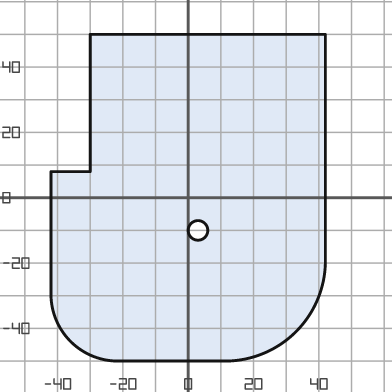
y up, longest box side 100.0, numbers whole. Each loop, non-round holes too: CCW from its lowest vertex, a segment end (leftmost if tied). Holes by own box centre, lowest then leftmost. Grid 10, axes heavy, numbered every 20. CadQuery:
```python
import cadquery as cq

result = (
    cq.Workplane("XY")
    .moveTo(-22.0, -50.0)
    .lineTo(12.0, -50.0)
    .threePointArc((33.0, -41.0), (42.0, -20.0))
    .lineTo(42.0, 50.0)
    .lineTo(-30.0, 50.0)
    .lineTo(-30.0, 8.0)
    .lineTo(-42.0, 8.0)
    .lineTo(-42.0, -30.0)
    .threePointArc((-36.0, -44.0), (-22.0, -50.0))
    .close()
    .moveTo(3.0, -10.0)
    .circle(3.0)
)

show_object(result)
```